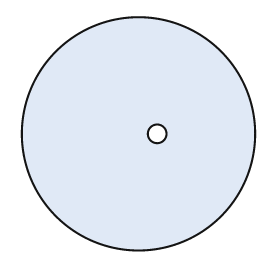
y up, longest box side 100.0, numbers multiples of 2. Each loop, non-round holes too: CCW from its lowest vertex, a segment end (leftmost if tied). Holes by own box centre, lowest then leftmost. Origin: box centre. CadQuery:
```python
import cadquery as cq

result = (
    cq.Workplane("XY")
    .moveTo(0.0, 0.0)
    .circle(50.0)
    .moveTo(8.0, 0.0)
    .circle(4.0)
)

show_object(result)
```